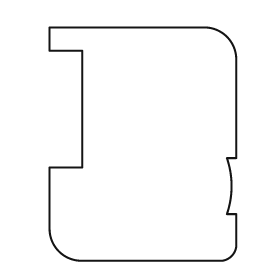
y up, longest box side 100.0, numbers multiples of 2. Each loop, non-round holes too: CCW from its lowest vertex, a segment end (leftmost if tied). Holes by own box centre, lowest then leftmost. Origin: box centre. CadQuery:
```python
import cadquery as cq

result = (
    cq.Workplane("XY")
    .moveTo(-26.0, -50.0)
    .lineTo(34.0, -50.0)
    .threePointArc((38.0, -48.0), (40.0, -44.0))
    .lineTo(40.0, -30.0)
    .lineTo(36.0, -30.0)
    .threePointArc((38.0, -18.0), (36.0, -6.0))
    .lineTo(40.0, -6.0)
    .lineTo(40.0, 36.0)
    .threePointArc((36.0, 46.0), (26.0, 50.0))
    .lineTo(-40.0, 50.0)
    .lineTo(-40.0, 40.0)
    .lineTo(-26.0, 40.0)
    .lineTo(-26.0, -10.0)
    .lineTo(-40.0, -10.0)
    .lineTo(-40.0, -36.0)
    .threePointArc((-36.0, -46.0), (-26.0, -50.0))
    .close()
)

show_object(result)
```